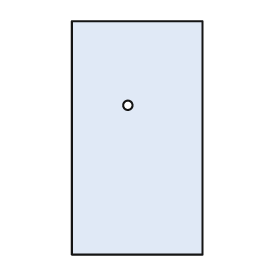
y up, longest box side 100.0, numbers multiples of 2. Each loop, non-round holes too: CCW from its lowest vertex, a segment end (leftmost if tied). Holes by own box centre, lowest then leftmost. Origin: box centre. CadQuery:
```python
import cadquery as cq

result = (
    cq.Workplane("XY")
    .moveTo(-28.0, -50.0)
    .lineTo(28.0, -50.0)
    .lineTo(28.0, 50.0)
    .lineTo(-28.0, 50.0)
    .close()
    .moveTo(-4.0, 14.0)
    .circle(2.0)
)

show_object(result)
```